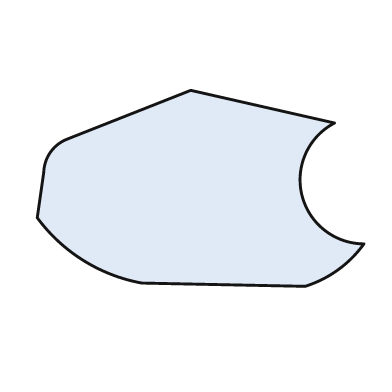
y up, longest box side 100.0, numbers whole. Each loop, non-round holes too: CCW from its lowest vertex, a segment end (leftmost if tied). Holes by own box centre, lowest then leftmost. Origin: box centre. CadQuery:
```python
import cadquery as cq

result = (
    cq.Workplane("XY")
    .moveTo(32.0, -30.0)
    .threePointArc((42.0, -25.0), (50.0, -17.0))
    .threePointArc((31.0, -2.0), (41.0, 20.0))
    .lineTo(-3.0, 30.0)
    .lineTo(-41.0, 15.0)
    .threePointArc((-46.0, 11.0), (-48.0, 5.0))
    .lineTo(-50.0, -9.0)
    .threePointArc((-36.0, -22.0), (-18.0, -29.0))
    .close()
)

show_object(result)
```